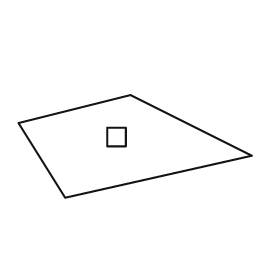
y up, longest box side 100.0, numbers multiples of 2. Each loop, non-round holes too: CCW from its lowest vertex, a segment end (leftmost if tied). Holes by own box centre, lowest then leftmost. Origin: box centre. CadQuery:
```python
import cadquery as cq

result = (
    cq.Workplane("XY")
    .moveTo(-30.0, -22.0)
    .lineTo(50.0, -4.0)
    .lineTo(-2.0, 22.0)
    .lineTo(-50.0, 10.0)
    .close()
    .moveTo(-12.0, 0.0)
    .lineTo(-4.0, 0.0)
    .lineTo(-4.0, 8.0)
    .lineTo(-12.0, 8.0)
    .close()
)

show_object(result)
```